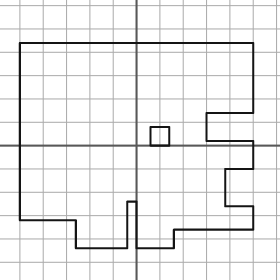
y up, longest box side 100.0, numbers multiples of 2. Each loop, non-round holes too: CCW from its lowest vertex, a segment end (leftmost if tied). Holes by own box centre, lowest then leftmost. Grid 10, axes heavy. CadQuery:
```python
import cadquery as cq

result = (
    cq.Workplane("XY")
    .moveTo(-26.0, -44.0)
    .lineTo(-4.0, -44.0)
    .lineTo(-4.0, -24.0)
    .lineTo(0.0, -24.0)
    .lineTo(0.0, -44.0)
    .lineTo(16.0, -44.0)
    .lineTo(16.0, -36.0)
    .lineTo(50.0, -36.0)
    .lineTo(50.0, -26.0)
    .lineTo(38.0, -26.0)
    .lineTo(38.0, -10.0)
    .lineTo(50.0, -10.0)
    .lineTo(50.0, 2.0)
    .lineTo(30.0, 2.0)
    .lineTo(30.0, 14.0)
    .lineTo(50.0, 14.0)
    .lineTo(50.0, 44.0)
    .lineTo(-50.0, 44.0)
    .lineTo(-50.0, -32.0)
    .lineTo(-26.0, -32.0)
    .close()
    .moveTo(6.0, 0.0)
    .lineTo(14.0, 0.0)
    .lineTo(14.0, 8.0)
    .lineTo(6.0, 8.0)
    .close()
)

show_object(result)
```